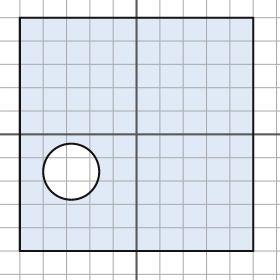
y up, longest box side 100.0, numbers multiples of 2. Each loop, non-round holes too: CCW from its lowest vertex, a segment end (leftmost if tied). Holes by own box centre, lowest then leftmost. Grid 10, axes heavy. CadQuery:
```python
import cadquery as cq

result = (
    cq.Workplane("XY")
    .moveTo(-50.0, -50.0)
    .lineTo(50.0, -50.0)
    .lineTo(50.0, 50.0)
    .lineTo(-50.0, 50.0)
    .close()
    .moveTo(-28.0, -16.0)
    .circle(12.0)
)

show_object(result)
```